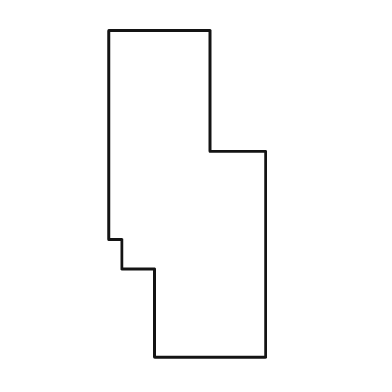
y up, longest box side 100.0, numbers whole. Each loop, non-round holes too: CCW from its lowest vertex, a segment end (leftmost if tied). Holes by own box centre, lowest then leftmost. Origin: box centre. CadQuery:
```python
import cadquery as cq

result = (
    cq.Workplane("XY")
    .moveTo(-10.0, -50.0)
    .lineTo(24.0, -50.0)
    .lineTo(24.0, 13.0)
    .lineTo(7.0, 13.0)
    .lineTo(7.0, 50.0)
    .lineTo(-24.0, 50.0)
    .lineTo(-24.0, -14.0)
    .lineTo(-20.0, -14.0)
    .lineTo(-20.0, -23.0)
    .lineTo(-10.0, -23.0)
    .close()
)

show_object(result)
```